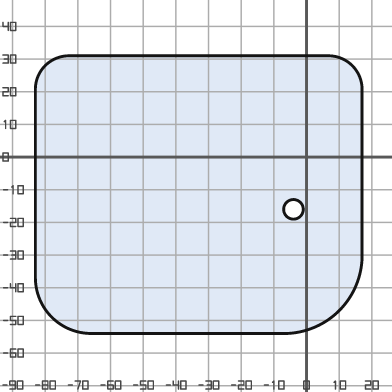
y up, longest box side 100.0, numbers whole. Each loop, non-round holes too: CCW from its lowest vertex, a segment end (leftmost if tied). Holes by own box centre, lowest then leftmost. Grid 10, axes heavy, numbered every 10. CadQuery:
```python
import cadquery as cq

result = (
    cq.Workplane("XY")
    .moveTo(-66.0, -54.0)
    .lineTo(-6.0, -54.0)
    .threePointArc((10.0, -47.0), (17.0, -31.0))
    .lineTo(17.0, 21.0)
    .threePointArc((14.0, 28.0), (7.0, 31.0))
    .lineTo(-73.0, 31.0)
    .threePointArc((-80.0, 28.0), (-83.0, 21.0))
    .lineTo(-83.0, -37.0)
    .threePointArc((-78.0, -49.0), (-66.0, -54.0))
    .close()
    .moveTo(-4.0, -16.0)
    .circle(3.0)
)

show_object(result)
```